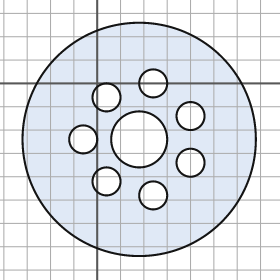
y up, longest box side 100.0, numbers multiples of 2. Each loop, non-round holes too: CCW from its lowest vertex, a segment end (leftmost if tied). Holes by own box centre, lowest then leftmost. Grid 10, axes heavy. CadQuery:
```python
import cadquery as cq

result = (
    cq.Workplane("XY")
    .moveTo(18.0, -24.0)
    .circle(50.0)
    .moveTo(24.0, -48.0)
    .circle(6.0)
    .moveTo(4.0, -42.0)
    .circle(6.0)
    .moveTo(40.0, -34.0)
    .circle(6.0)
    .moveTo(-6.0, -24.0)
    .circle(6.0)
    .moveTo(18.0, -24.0)
    .circle(12.0)
    .moveTo(40.0, -14.0)
    .circle(6.0)
    .moveTo(4.0, -6.0)
    .circle(6.0)
    .moveTo(24.0, 0.0)
    .circle(6.0)
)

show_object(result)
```